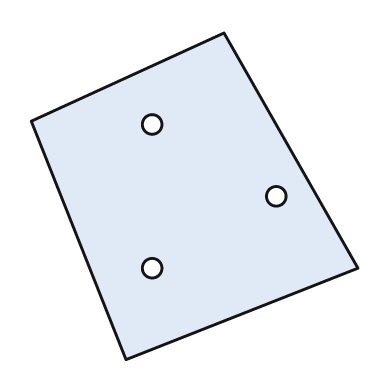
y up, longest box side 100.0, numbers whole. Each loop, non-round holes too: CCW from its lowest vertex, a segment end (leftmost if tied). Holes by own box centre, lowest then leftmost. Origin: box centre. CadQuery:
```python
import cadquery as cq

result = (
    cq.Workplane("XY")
    .moveTo(-21.0, -50.0)
    .lineTo(50.0, -22.0)
    .lineTo(9.0, 50.0)
    .lineTo(-50.0, 23.0)
    .close()
    .moveTo(-13.0, -22.0)
    .circle(3.0)
    .moveTo(25.0, 0.0)
    .circle(3.0)
    .moveTo(-13.0, 22.0)
    .circle(3.0)
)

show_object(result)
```